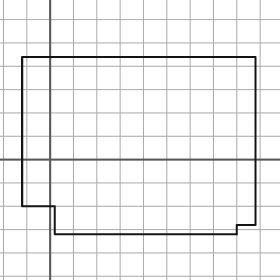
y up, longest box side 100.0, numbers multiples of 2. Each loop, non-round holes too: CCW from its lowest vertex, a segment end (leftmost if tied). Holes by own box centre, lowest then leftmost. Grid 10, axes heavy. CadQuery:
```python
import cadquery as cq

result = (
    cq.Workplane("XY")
    .moveTo(2.0, -32.0)
    .lineTo(80.0, -32.0)
    .lineTo(80.0, -28.0)
    .lineTo(88.0, -28.0)
    .lineTo(88.0, 44.0)
    .lineTo(-12.0, 44.0)
    .lineTo(-12.0, -20.0)
    .lineTo(2.0, -20.0)
    .close()
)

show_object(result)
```